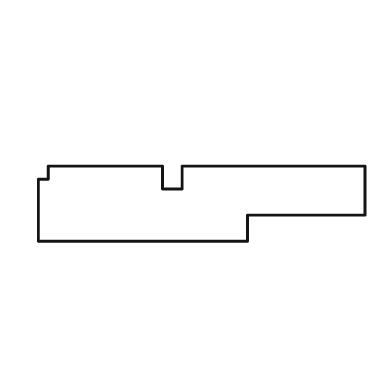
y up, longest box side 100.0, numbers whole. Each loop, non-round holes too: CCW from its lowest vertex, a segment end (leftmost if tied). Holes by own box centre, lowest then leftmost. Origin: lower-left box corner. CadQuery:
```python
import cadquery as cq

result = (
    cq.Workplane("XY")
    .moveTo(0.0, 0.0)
    .lineTo(64.0, 0.0)
    .lineTo(64.0, 8.0)
    .lineTo(100.0, 8.0)
    .lineTo(100.0, 23.0)
    .lineTo(44.0, 23.0)
    .lineTo(44.0, 16.0)
    .lineTo(38.0, 16.0)
    .lineTo(38.0, 23.0)
    .lineTo(3.0, 23.0)
    .lineTo(3.0, 19.0)
    .lineTo(0.0, 19.0)
    .close()
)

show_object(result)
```